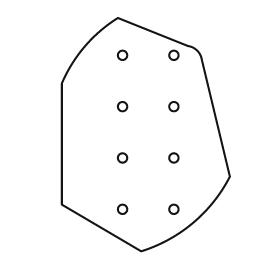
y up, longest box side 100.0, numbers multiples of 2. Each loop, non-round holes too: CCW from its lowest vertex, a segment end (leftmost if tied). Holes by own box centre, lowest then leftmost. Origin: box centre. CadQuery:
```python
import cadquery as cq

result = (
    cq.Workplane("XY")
    .moveTo(-2.0, -50.0)
    .threePointArc((20.0, -38.0), (36.0, -18.0))
    .lineTo(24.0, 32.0)
    .threePointArc((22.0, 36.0), (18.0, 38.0))
    .lineTo(-12.0, 50.0)
    .threePointArc((-26.0, 38.0), (-36.0, 22.0))
    .lineTo(-36.0, -30.0)
    .close()
    .moveTo(-10.0, -32.0)
    .circle(2.0)
    .moveTo(12.0, -32.0)
    .circle(2.0)
    .moveTo(-10.0, -10.0)
    .circle(2.0)
    .moveTo(12.0, -10.0)
    .circle(2.0)
    .moveTo(-10.0, 12.0)
    .circle(2.0)
    .moveTo(12.0, 12.0)
    .circle(2.0)
    .moveTo(-10.0, 34.0)
    .circle(2.0)
    .moveTo(12.0, 34.0)
    .circle(2.0)
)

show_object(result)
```